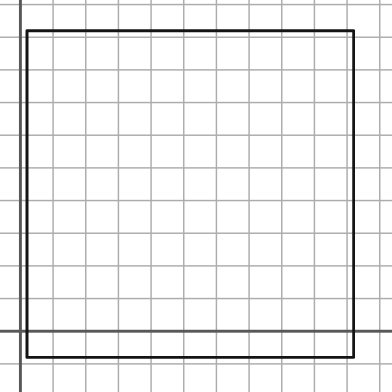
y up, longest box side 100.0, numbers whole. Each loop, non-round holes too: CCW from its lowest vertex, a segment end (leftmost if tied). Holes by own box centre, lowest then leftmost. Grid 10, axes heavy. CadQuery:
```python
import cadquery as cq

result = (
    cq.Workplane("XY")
    .moveTo(2.0, -8.0)
    .lineTo(102.0, -8.0)
    .lineTo(102.0, 92.0)
    .lineTo(2.0, 92.0)
    .close()
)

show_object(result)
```